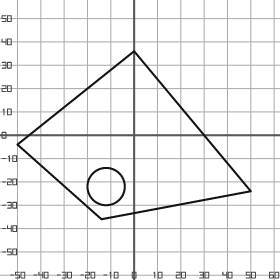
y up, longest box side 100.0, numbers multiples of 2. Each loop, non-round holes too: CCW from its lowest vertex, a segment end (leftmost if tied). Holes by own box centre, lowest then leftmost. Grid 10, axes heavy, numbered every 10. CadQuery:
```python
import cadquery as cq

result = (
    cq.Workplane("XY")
    .moveTo(-14.0, -36.0)
    .lineTo(50.0, -24.0)
    .lineTo(0.0, 36.0)
    .lineTo(-50.0, -4.0)
    .close()
    .moveTo(-12.0, -22.0)
    .circle(8.0)
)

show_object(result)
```